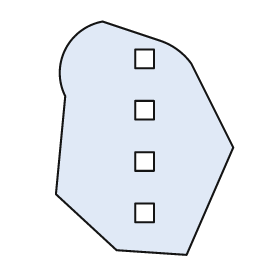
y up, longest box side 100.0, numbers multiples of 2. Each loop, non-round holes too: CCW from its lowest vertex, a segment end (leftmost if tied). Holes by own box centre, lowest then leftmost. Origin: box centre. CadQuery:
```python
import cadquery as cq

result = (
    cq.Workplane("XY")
    .moveTo(18.0, -50.0)
    .lineTo(38.0, -4.0)
    .lineTo(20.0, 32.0)
    .threePointArc((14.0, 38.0), (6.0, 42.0))
    .lineTo(-18.0, 50.0)
    .threePointArc((-34.0, 38.0), (-34.0, 18.0))
    .lineTo(-38.0, -24.0)
    .lineTo(-12.0, -48.0)
    .close()
    .moveTo(-4.0, -36.0)
    .lineTo(4.0, -36.0)
    .lineTo(4.0, -28.0)
    .lineTo(-4.0, -28.0)
    .close()
    .moveTo(-4.0, -14.0)
    .lineTo(4.0, -14.0)
    .lineTo(4.0, -6.0)
    .lineTo(-4.0, -6.0)
    .close()
    .moveTo(-4.0, 8.0)
    .lineTo(4.0, 8.0)
    .lineTo(4.0, 16.0)
    .lineTo(-4.0, 16.0)
    .close()
    .moveTo(-4.0, 30.0)
    .lineTo(4.0, 30.0)
    .lineTo(4.0, 38.0)
    .lineTo(-4.0, 38.0)
    .close()
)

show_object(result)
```